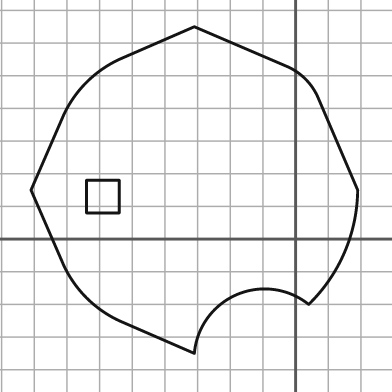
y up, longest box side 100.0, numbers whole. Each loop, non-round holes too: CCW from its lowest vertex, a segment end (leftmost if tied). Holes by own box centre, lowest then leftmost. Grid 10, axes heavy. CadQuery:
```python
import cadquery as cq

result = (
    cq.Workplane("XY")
    .moveTo(-31.0, -35.0)
    .threePointArc((-18.0, -17.0), (4.0, -20.0))
    .threePointArc((15.0, -4.0), (19.0, 15.0))
    .lineTo(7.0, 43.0)
    .threePointArc((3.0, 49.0), (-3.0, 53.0))
    .lineTo(-31.0, 65.0)
    .lineTo(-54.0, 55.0)
    .threePointArc((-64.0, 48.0), (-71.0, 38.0))
    .lineTo(-81.0, 15.0)
    .lineTo(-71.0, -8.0)
    .threePointArc((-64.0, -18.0), (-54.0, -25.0))
    .close()
    .moveTo(-64.0, 8.0)
    .lineTo(-54.0, 8.0)
    .lineTo(-54.0, 18.0)
    .lineTo(-64.0, 18.0)
    .close()
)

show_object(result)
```